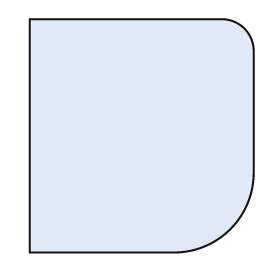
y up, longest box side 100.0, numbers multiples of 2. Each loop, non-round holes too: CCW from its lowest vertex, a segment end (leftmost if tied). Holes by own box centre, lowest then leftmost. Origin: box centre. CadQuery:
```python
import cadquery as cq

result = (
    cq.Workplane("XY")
    .moveTo(-48.0, -50.0)
    .lineTo(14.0, -50.0)
    .threePointArc((38.0, -40.0), (48.0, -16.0))
    .lineTo(48.0, 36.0)
    .threePointArc((44.0, 46.0), (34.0, 50.0))
    .lineTo(-48.0, 50.0)
    .close()
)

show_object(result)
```